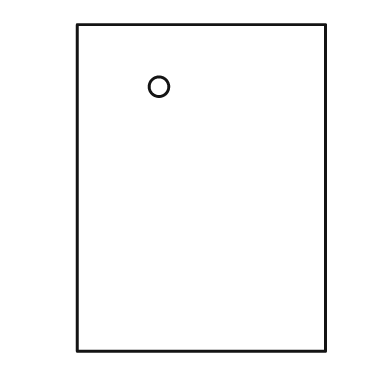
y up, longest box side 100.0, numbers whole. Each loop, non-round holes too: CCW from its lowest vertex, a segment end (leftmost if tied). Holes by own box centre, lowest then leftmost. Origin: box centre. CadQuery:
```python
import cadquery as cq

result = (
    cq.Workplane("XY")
    .moveTo(-38.0, -50.0)
    .lineTo(38.0, -50.0)
    .lineTo(38.0, 50.0)
    .lineTo(-38.0, 50.0)
    .close()
    .moveTo(-13.0, 31.0)
    .circle(3.0)
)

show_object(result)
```